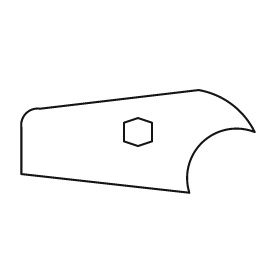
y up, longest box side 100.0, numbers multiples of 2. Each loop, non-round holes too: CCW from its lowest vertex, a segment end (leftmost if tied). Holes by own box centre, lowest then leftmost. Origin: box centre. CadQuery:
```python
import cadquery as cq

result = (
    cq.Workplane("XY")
    .moveTo(22.0, -22.0)
    .threePointArc((28.0, 0.0), (50.0, 4.0))
    .threePointArc((40.0, 16.0), (26.0, 22.0))
    .lineTo(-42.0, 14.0)
    .threePointArc((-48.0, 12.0), (-50.0, 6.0))
    .lineTo(-50.0, -14.0)
    .close()
    .moveTo(0.0, -2.0)
    .lineTo(6.0, 0.0)
    .lineTo(6.0, 8.0)
    .lineTo(0.0, 10.0)
    .lineTo(-6.0, 8.0)
    .lineTo(-6.0, 0.0)
    .close()
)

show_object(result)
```